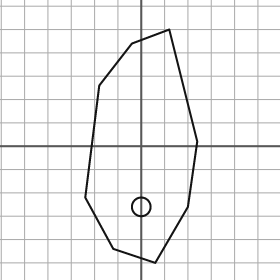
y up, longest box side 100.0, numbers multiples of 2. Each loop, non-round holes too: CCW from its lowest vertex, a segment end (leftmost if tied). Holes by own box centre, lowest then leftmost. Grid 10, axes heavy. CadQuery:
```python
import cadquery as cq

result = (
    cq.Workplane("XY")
    .moveTo(6.0, -50.0)
    .lineTo(20.0, -26.0)
    .lineTo(24.0, 2.0)
    .lineTo(12.0, 50.0)
    .lineTo(-4.0, 44.0)
    .lineTo(-18.0, 26.0)
    .lineTo(-24.0, -22.0)
    .lineTo(-12.0, -44.0)
    .close()
    .moveTo(0.0, -26.0)
    .circle(4.0)
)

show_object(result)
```